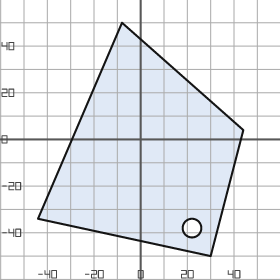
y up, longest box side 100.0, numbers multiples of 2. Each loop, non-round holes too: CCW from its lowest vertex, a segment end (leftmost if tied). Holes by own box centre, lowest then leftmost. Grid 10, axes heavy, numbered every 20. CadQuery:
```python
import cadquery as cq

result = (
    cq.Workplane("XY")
    .moveTo(30.0, -50.0)
    .lineTo(44.0, 4.0)
    .lineTo(-8.0, 50.0)
    .lineTo(-44.0, -34.0)
    .close()
    .moveTo(22.0, -38.0)
    .circle(4.0)
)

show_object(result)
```